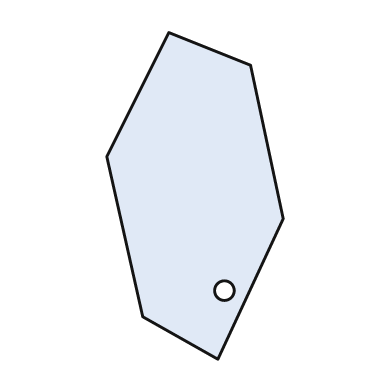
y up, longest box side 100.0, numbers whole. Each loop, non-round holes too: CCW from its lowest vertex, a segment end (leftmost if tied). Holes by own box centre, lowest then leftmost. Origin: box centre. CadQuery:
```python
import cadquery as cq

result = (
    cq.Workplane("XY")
    .moveTo(7.0, -50.0)
    .lineTo(27.0, -7.0)
    .lineTo(17.0, 40.0)
    .lineTo(-8.0, 50.0)
    .lineTo(-27.0, 12.0)
    .lineTo(-16.0, -37.0)
    .close()
    .moveTo(9.0, -29.0)
    .circle(3.0)
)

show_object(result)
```